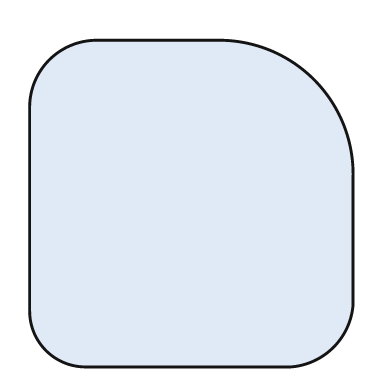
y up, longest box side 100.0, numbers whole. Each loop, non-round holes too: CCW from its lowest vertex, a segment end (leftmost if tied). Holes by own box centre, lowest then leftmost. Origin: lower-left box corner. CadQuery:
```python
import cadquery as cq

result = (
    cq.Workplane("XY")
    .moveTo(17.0, 0.0)
    .lineTo(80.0, 0.0)
    .threePointArc((93.0, 6.0), (99.0, 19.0))
    .lineTo(99.0, 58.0)
    .threePointArc((87.0, 88.0), (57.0, 100.0))
    .lineTo(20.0, 100.0)
    .threePointArc((6.0, 94.0), (0.0, 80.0))
    .lineTo(0.0, 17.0)
    .threePointArc((5.0, 5.0), (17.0, 0.0))
    .close()
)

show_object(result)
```